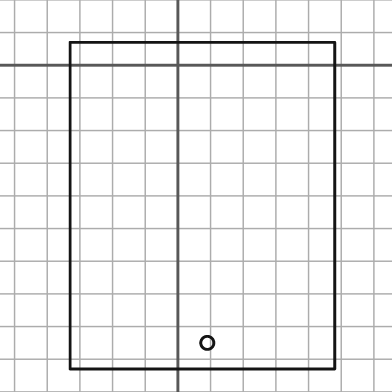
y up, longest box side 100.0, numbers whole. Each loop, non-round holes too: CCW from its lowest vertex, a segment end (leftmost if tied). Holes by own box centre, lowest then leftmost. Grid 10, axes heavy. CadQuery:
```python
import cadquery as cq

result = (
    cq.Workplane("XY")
    .moveTo(-33.0, -93.0)
    .lineTo(48.0, -93.0)
    .lineTo(48.0, 7.0)
    .lineTo(-33.0, 7.0)
    .close()
    .moveTo(9.0, -85.0)
    .circle(2.0)
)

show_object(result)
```